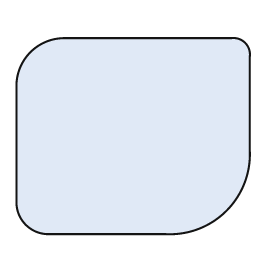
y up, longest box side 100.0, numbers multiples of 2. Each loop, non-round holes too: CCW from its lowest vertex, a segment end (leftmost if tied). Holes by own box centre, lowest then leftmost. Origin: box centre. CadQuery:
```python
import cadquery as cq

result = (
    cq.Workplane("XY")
    .moveTo(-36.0, -42.0)
    .lineTo(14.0, -42.0)
    .threePointArc((40.0, -32.0), (50.0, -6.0))
    .lineTo(50.0, 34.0)
    .threePointArc((48.0, 40.0), (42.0, 42.0))
    .lineTo(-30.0, 42.0)
    .threePointArc((-44.0, 36.0), (-50.0, 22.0))
    .lineTo(-50.0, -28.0)
    .threePointArc((-46.0, -38.0), (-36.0, -42.0))
    .close()
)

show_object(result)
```